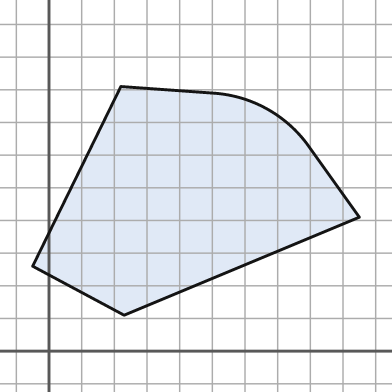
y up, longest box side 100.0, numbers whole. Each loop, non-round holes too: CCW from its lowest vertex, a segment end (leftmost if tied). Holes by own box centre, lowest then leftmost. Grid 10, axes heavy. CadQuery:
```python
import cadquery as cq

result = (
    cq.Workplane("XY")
    .moveTo(23.0, 11.0)
    .lineTo(95.0, 41.0)
    .lineTo(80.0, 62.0)
    .threePointArc((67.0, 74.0), (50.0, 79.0))
    .lineTo(22.0, 81.0)
    .lineTo(-5.0, 26.0)
    .close()
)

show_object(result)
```